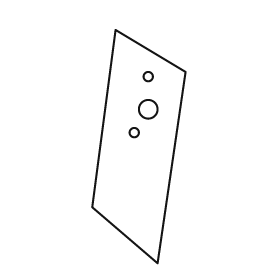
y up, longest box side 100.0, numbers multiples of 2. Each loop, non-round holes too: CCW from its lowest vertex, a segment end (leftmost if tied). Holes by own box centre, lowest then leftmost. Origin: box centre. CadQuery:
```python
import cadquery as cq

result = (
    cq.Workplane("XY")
    .moveTo(8.0, -50.0)
    .lineTo(20.0, 32.0)
    .lineTo(-10.0, 50.0)
    .lineTo(-20.0, -26.0)
    .close()
    .moveTo(-2.0, 6.0)
    .circle(2.0)
    .moveTo(4.0, 16.0)
    .circle(4.0)
    .moveTo(4.0, 30.0)
    .circle(2.0)
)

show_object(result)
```